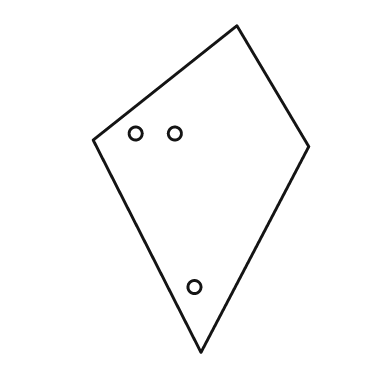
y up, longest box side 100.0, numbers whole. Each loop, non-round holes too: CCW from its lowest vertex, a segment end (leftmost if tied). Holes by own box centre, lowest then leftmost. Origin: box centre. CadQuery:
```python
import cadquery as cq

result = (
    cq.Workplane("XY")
    .moveTo(0.0, -50.0)
    .lineTo(33.0, 13.0)
    .lineTo(11.0, 50.0)
    .lineTo(-33.0, 15.0)
    .close()
    .moveTo(-2.0, -30.0)
    .circle(2.0)
    .moveTo(-20.0, 17.0)
    .circle(2.0)
    .moveTo(-8.0, 17.0)
    .circle(2.0)
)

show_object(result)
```